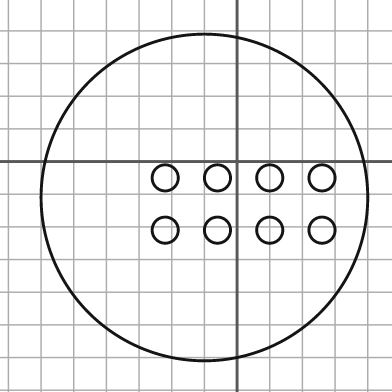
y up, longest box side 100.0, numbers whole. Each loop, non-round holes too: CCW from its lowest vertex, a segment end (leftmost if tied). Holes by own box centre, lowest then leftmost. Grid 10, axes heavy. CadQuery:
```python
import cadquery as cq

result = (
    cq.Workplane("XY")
    .moveTo(-10.0, -11.0)
    .circle(50.0)
    .moveTo(-22.0, -21.0)
    .circle(4.0)
    .moveTo(-6.0, -21.0)
    .circle(4.0)
    .moveTo(10.0, -21.0)
    .circle(4.0)
    .moveTo(26.0, -21.0)
    .circle(4.0)
    .moveTo(-22.0, -5.0)
    .circle(4.0)
    .moveTo(-6.0, -5.0)
    .circle(4.0)
    .moveTo(10.0, -5.0)
    .circle(4.0)
    .moveTo(26.0, -5.0)
    .circle(4.0)
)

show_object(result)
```